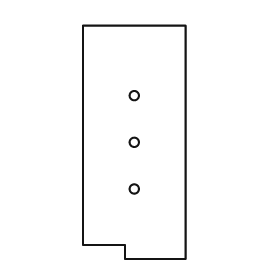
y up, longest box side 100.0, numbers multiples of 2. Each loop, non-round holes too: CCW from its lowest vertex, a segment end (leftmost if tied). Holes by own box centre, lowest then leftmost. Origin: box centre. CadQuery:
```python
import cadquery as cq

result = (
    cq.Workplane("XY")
    .moveTo(-4.0, -50.0)
    .lineTo(22.0, -50.0)
    .lineTo(22.0, 50.0)
    .lineTo(-22.0, 50.0)
    .lineTo(-22.0, -44.0)
    .lineTo(-4.0, -44.0)
    .close()
    .moveTo(0.0, -20.0)
    .circle(2.0)
    .moveTo(0.0, 0.0)
    .circle(2.0)
    .moveTo(0.0, 20.0)
    .circle(2.0)
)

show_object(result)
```